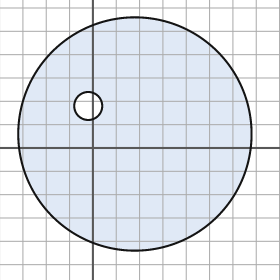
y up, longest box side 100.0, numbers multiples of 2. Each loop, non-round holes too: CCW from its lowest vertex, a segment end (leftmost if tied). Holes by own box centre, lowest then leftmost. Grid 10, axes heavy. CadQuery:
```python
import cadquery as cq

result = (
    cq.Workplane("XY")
    .moveTo(18.0, 6.0)
    .circle(50.0)
    .moveTo(-2.0, 18.0)
    .circle(6.0)
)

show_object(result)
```